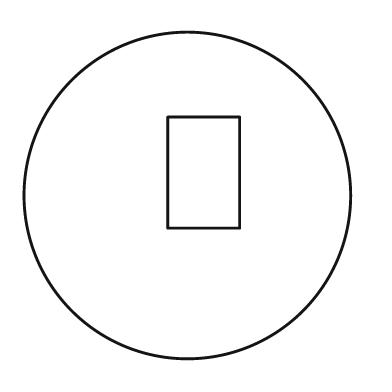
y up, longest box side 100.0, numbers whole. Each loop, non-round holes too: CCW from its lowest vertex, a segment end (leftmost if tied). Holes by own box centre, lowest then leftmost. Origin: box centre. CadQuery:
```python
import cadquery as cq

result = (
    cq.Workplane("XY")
    .moveTo(0.0, 0.0)
    .circle(50.0)
    .moveTo(-6.0, -10.0)
    .lineTo(16.0, -10.0)
    .lineTo(16.0, 24.0)
    .lineTo(-6.0, 24.0)
    .close()
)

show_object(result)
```